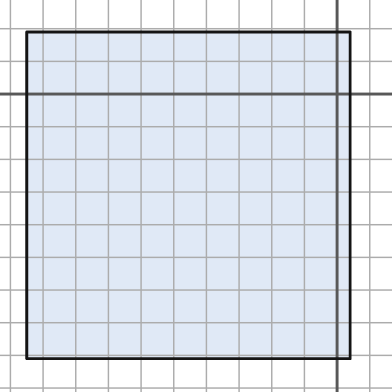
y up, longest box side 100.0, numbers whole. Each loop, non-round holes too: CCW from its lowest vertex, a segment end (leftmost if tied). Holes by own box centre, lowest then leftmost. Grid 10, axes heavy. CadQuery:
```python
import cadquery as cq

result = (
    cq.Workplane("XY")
    .moveTo(-95.0, -81.0)
    .lineTo(4.0, -81.0)
    .lineTo(4.0, 19.0)
    .lineTo(-95.0, 19.0)
    .close()
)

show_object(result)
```